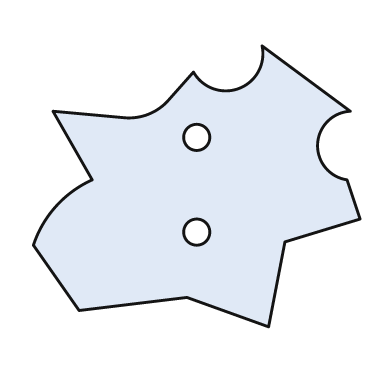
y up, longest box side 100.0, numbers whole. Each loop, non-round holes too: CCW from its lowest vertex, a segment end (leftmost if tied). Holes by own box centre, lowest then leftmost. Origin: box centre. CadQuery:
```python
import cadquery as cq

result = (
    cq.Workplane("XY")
    .moveTo(22.0, -43.0)
    .lineTo(27.0, -17.0)
    .lineTo(50.0, -10.0)
    .lineTo(46.0, 2.0)
    .threePointArc((37.0, 13.0), (47.0, 23.0))
    .lineTo(20.0, 43.0)
    .threePointArc((13.0, 30.0), (-1.0, 35.0))
    .lineTo(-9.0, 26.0)
    .threePointArc((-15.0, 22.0), (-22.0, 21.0))
    .lineTo(-44.0, 23.0)
    .lineTo(-32.0, 2.0)
    .threePointArc((-43.0, -6.0), (-50.0, -18.0))
    .lineTo(-36.0, -38.0)
    .lineTo(-3.0, -34.0)
    .close()
    .moveTo(0.0, -14.0)
    .circle(4.0)
    .moveTo(0.0, 15.0)
    .circle(4.0)
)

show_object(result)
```